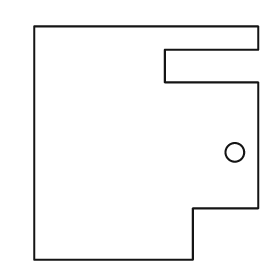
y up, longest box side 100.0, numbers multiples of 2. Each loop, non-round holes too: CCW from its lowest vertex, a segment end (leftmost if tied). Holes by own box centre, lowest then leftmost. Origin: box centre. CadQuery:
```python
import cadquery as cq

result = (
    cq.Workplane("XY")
    .moveTo(-48.0, -50.0)
    .lineTo(20.0, -50.0)
    .lineTo(20.0, -28.0)
    .lineTo(48.0, -28.0)
    .lineTo(48.0, 26.0)
    .lineTo(8.0, 26.0)
    .lineTo(8.0, 40.0)
    .lineTo(48.0, 40.0)
    .lineTo(48.0, 50.0)
    .lineTo(-48.0, 50.0)
    .close()
    .moveTo(38.0, -4.0)
    .circle(4.0)
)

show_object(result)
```